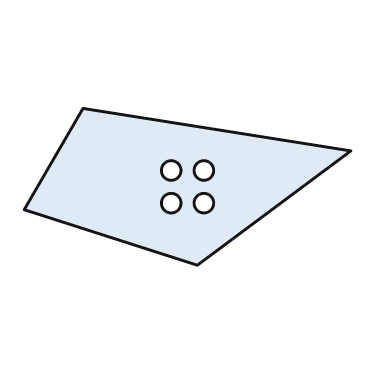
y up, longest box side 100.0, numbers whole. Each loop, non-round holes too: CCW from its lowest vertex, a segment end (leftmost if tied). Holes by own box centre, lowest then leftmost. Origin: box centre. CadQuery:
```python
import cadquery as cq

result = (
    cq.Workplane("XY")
    .moveTo(3.0, -24.0)
    .lineTo(50.0, 11.0)
    .lineTo(-32.0, 24.0)
    .lineTo(-50.0, -7.0)
    .close()
    .moveTo(-5.0, -5.0)
    .circle(3.0)
    .moveTo(5.0, -5.0)
    .circle(3.0)
    .moveTo(-5.0, 5.0)
    .circle(3.0)
    .moveTo(5.0, 5.0)
    .circle(3.0)
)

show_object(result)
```